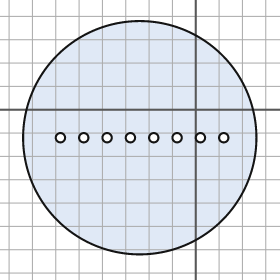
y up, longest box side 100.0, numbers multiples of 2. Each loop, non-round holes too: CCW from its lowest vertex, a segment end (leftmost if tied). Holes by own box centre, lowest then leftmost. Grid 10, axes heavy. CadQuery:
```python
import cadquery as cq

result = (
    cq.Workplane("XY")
    .moveTo(-24.0, -12.0)
    .circle(50.0)
    .moveTo(-58.0, -12.0)
    .circle(2.0)
    .moveTo(-48.0, -12.0)
    .circle(2.0)
    .moveTo(-38.0, -12.0)
    .circle(2.0)
    .moveTo(-28.0, -12.0)
    .circle(2.0)
    .moveTo(-18.0, -12.0)
    .circle(2.0)
    .moveTo(-8.0, -12.0)
    .circle(2.0)
    .moveTo(2.0, -12.0)
    .circle(2.0)
    .moveTo(12.0, -12.0)
    .circle(2.0)
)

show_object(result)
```